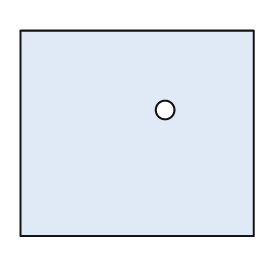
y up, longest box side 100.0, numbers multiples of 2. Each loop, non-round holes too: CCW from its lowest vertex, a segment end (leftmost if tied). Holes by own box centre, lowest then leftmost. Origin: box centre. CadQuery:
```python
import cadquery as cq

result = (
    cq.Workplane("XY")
    .moveTo(-50.0, -44.0)
    .lineTo(50.0, -44.0)
    .lineTo(50.0, 44.0)
    .lineTo(-50.0, 44.0)
    .close()
    .moveTo(12.0, 10.0)
    .circle(4.0)
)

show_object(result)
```